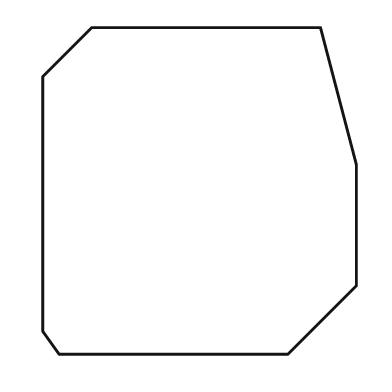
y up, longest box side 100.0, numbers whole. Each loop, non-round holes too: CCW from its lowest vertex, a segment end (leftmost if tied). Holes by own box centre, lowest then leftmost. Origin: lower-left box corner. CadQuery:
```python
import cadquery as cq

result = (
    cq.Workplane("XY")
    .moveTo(5.0, 0.0)
    .lineTo(75.0, 0.0)
    .lineTo(96.0, 21.0)
    .lineTo(96.0, 58.0)
    .lineTo(85.0, 100.0)
    .lineTo(15.0, 100.0)
    .lineTo(0.0, 85.0)
    .lineTo(0.0, 7.0)
    .close()
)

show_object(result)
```